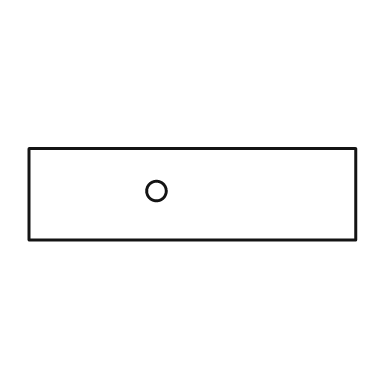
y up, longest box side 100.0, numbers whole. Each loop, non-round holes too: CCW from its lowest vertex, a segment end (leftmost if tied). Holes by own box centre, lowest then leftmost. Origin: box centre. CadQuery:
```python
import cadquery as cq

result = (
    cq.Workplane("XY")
    .moveTo(-50.0, -14.0)
    .lineTo(50.0, -14.0)
    .lineTo(50.0, 14.0)
    .lineTo(-50.0, 14.0)
    .close()
    .moveTo(-11.0, 1.0)
    .circle(3.0)
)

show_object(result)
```